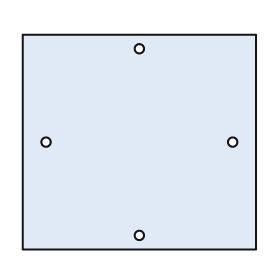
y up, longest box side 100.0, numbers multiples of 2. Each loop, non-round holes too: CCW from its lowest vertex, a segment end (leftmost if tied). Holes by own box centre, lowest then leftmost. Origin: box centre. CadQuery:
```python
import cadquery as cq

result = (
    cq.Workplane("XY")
    .moveTo(-50.0, -46.0)
    .lineTo(50.0, -46.0)
    .lineTo(50.0, 46.0)
    .lineTo(-50.0, 46.0)
    .close()
    .moveTo(0.0, -40.0)
    .circle(2.0)
    .moveTo(-40.0, 0.0)
    .circle(2.0)
    .moveTo(40.0, 0.0)
    .circle(2.0)
    .moveTo(0.0, 40.0)
    .circle(2.0)
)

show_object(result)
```